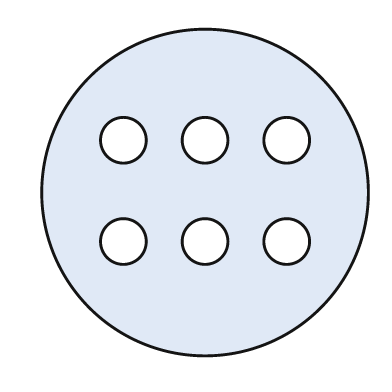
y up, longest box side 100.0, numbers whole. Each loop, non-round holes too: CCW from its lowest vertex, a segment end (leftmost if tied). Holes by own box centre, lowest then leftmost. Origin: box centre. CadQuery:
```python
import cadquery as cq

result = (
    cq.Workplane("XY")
    .moveTo(0.0, 0.0)
    .circle(50.0)
    .moveTo(-25.0, -15.0)
    .circle(7.0)
    .moveTo(0.0, -15.0)
    .circle(7.0)
    .moveTo(25.0, -15.0)
    .circle(7.0)
    .moveTo(-25.0, 16.0)
    .circle(7.0)
    .moveTo(0.0, 16.0)
    .circle(7.0)
    .moveTo(25.0, 16.0)
    .circle(7.0)
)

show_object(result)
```